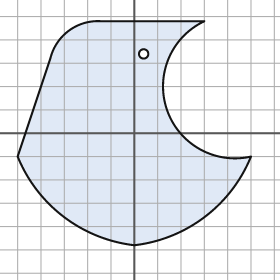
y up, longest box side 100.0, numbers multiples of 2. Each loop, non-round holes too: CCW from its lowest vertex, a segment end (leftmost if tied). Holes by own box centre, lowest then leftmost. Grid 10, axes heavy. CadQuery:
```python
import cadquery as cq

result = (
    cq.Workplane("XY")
    .moveTo(0.0, -48.0)
    .threePointArc((30.0, -36.0), (50.0, -10.0))
    .threePointArc((14.0, 10.0), (30.0, 48.0))
    .lineTo(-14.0, 48.0)
    .threePointArc((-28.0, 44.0), (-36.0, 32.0))
    .lineTo(-50.0, -10.0)
    .threePointArc((-30.0, -36.0), (0.0, -48.0))
    .close()
    .moveTo(4.0, 34.0)
    .circle(2.0)
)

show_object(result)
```